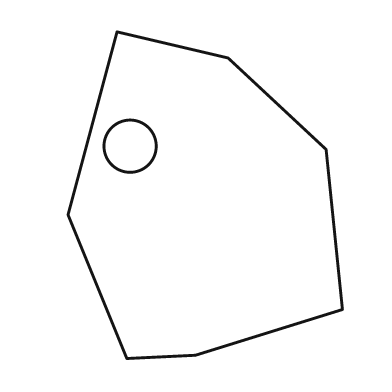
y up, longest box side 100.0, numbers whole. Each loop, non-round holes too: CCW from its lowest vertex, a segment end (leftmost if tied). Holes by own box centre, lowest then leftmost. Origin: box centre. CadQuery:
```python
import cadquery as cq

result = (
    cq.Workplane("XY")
    .moveTo(-24.0, -50.0)
    .lineTo(-3.0, -49.0)
    .lineTo(42.0, -35.0)
    .lineTo(37.0, 14.0)
    .lineTo(7.0, 42.0)
    .lineTo(-27.0, 50.0)
    .lineTo(-42.0, -6.0)
    .close()
    .moveTo(-23.0, 15.0)
    .circle(8.0)
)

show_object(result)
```